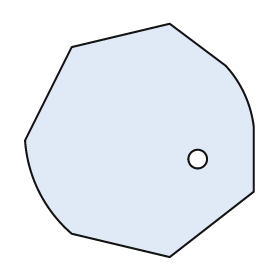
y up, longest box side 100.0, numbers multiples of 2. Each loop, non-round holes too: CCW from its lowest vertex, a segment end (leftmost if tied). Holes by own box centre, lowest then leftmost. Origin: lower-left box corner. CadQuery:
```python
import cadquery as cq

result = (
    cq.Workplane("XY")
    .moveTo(62.0, 0.0)
    .lineTo(98.0, 28.0)
    .lineTo(98.0, 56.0)
    .threePointArc((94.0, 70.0), (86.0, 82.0))
    .lineTo(62.0, 100.0)
    .lineTo(20.0, 90.0)
    .lineTo(0.0, 50.0)
    .threePointArc((6.0, 28.0), (20.0, 10.0))
    .close()
    .moveTo(74.0, 42.0)
    .circle(4.0)
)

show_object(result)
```